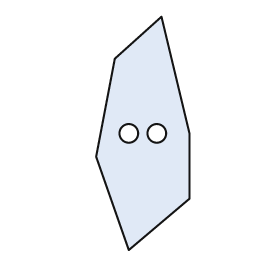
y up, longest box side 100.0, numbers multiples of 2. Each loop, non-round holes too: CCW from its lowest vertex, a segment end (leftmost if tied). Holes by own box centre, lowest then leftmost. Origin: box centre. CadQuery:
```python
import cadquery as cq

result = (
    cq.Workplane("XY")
    .moveTo(-6.0, -50.0)
    .lineTo(20.0, -28.0)
    .lineTo(20.0, 0.0)
    .lineTo(8.0, 50.0)
    .lineTo(-12.0, 32.0)
    .lineTo(-20.0, -10.0)
    .close()
    .moveTo(-6.0, 0.0)
    .circle(4.0)
    .moveTo(6.0, 0.0)
    .circle(4.0)
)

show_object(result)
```